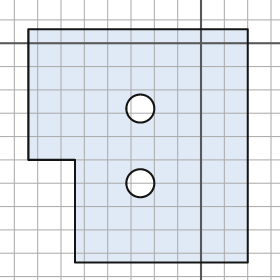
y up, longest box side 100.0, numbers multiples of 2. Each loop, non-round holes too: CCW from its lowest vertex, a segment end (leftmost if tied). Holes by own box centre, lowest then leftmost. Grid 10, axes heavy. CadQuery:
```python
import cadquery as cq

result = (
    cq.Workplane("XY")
    .moveTo(-54.0, -94.0)
    .lineTo(20.0, -94.0)
    .lineTo(20.0, 6.0)
    .lineTo(-74.0, 6.0)
    .lineTo(-74.0, -50.0)
    .lineTo(-54.0, -50.0)
    .close()
    .moveTo(-26.0, -60.0)
    .circle(6.0)
    .moveTo(-26.0, -28.0)
    .circle(6.0)
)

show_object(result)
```